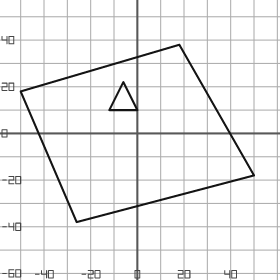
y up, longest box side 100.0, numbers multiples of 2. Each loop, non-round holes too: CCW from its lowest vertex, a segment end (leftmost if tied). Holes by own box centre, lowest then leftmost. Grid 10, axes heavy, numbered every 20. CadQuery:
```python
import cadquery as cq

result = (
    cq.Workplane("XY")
    .moveTo(-26.0, -38.0)
    .lineTo(50.0, -18.0)
    .lineTo(18.0, 38.0)
    .lineTo(-50.0, 18.0)
    .close()
    .moveTo(-12.0, 10.0)
    .lineTo(0.0, 10.0)
    .lineTo(-6.0, 22.0)
    .close()
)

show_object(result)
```